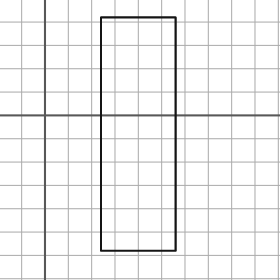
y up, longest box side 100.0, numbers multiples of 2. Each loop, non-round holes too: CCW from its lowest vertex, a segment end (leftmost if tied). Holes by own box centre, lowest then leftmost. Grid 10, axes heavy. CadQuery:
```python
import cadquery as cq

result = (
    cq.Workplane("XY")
    .moveTo(24.0, -58.0)
    .lineTo(56.0, -58.0)
    .lineTo(56.0, 42.0)
    .lineTo(24.0, 42.0)
    .close()
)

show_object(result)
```